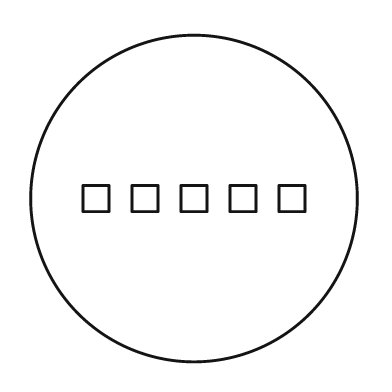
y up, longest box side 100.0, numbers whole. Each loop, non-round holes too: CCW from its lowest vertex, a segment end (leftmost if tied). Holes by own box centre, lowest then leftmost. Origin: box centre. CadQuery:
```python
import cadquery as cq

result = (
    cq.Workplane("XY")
    .moveTo(0.0, 0.0)
    .circle(50.0)
    .moveTo(-34.0, -4.0)
    .lineTo(-26.0, -4.0)
    .lineTo(-26.0, 4.0)
    .lineTo(-34.0, 4.0)
    .close()
    .moveTo(-19.0, -4.0)
    .lineTo(-11.0, -4.0)
    .lineTo(-11.0, 4.0)
    .lineTo(-19.0, 4.0)
    .close()
    .moveTo(-4.0, -4.0)
    .lineTo(4.0, -4.0)
    .lineTo(4.0, 4.0)
    .lineTo(-4.0, 4.0)
    .close()
    .moveTo(11.0, -4.0)
    .lineTo(19.0, -4.0)
    .lineTo(19.0, 4.0)
    .lineTo(11.0, 4.0)
    .close()
    .moveTo(26.0, -4.0)
    .lineTo(34.0, -4.0)
    .lineTo(34.0, 4.0)
    .lineTo(26.0, 4.0)
    .close()
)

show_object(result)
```